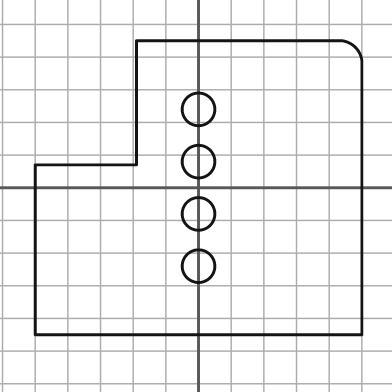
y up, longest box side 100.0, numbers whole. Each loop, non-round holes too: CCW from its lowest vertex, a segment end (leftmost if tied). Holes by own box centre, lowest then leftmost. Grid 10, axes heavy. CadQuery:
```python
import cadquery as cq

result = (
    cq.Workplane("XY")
    .moveTo(-50.0, -45.0)
    .lineTo(50.0, -45.0)
    .lineTo(50.0, 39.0)
    .threePointArc((48.0, 43.0), (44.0, 45.0))
    .lineTo(-19.0, 45.0)
    .lineTo(-19.0, 7.0)
    .lineTo(-50.0, 7.0)
    .close()
    .moveTo(0.0, -24.0)
    .circle(5.0)
    .moveTo(0.0, -8.0)
    .circle(5.0)
    .moveTo(0.0, 8.0)
    .circle(5.0)
    .moveTo(0.0, 24.0)
    .circle(5.0)
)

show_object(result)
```